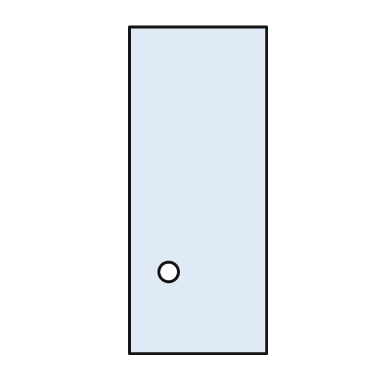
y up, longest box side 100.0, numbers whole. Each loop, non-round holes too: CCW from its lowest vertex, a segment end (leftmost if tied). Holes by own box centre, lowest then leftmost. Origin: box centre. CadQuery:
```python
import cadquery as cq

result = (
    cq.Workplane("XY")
    .moveTo(-21.0, -50.0)
    .lineTo(21.0, -50.0)
    .lineTo(21.0, 50.0)
    .lineTo(-21.0, 50.0)
    .close()
    .moveTo(-9.0, -25.0)
    .circle(3.0)
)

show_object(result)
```